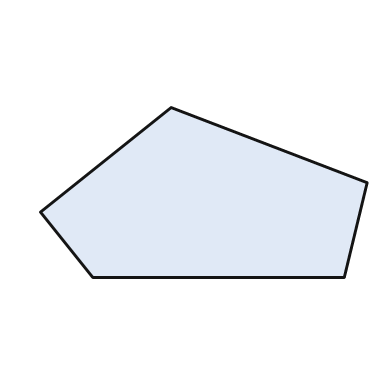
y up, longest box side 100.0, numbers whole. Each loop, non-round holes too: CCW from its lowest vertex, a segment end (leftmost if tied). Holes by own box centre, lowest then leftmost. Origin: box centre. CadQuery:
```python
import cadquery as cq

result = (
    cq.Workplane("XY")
    .moveTo(-34.0, -26.0)
    .lineTo(43.0, -26.0)
    .lineTo(50.0, 3.0)
    .lineTo(-10.0, 26.0)
    .lineTo(-50.0, -6.0)
    .close()
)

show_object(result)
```